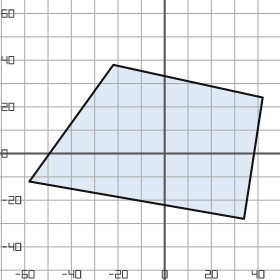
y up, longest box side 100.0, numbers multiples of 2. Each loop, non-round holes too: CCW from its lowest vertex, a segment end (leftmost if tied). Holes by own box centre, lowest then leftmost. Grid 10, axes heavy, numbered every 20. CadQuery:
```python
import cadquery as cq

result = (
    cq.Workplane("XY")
    .moveTo(34.0, -28.0)
    .lineTo(42.0, 24.0)
    .lineTo(-22.0, 38.0)
    .lineTo(-58.0, -12.0)
    .close()
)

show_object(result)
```